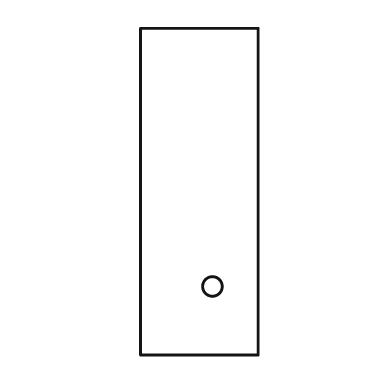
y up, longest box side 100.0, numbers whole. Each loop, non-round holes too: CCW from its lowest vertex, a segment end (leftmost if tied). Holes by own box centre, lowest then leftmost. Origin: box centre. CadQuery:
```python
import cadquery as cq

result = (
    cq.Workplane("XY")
    .moveTo(-18.0, -50.0)
    .lineTo(18.0, -50.0)
    .lineTo(18.0, 50.0)
    .lineTo(-18.0, 50.0)
    .close()
    .moveTo(4.0, -29.0)
    .circle(3.0)
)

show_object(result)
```